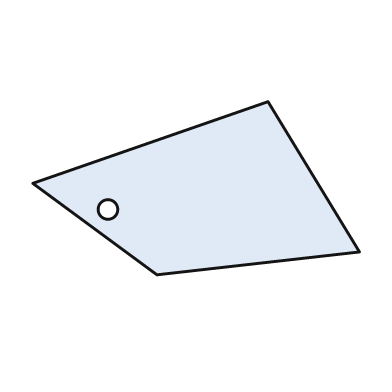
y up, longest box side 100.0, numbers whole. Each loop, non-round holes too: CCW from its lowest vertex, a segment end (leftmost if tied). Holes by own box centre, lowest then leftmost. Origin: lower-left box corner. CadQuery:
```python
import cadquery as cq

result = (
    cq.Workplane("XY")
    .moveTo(38.0, 0.0)
    .lineTo(100.0, 7.0)
    .lineTo(72.0, 53.0)
    .lineTo(0.0, 28.0)
    .close()
    .moveTo(23.0, 20.0)
    .circle(3.0)
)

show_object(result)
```